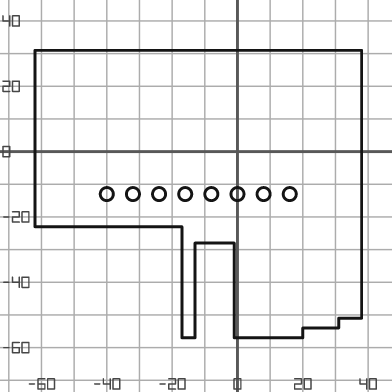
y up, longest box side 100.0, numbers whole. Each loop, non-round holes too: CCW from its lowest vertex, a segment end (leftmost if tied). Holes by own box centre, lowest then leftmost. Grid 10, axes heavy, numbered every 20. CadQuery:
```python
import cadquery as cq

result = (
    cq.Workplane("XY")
    .moveTo(-17.0, -57.0)
    .lineTo(-13.0, -57.0)
    .lineTo(-13.0, -28.0)
    .lineTo(-1.0, -28.0)
    .lineTo(-1.0, -57.0)
    .lineTo(20.0, -57.0)
    .lineTo(20.0, -54.0)
    .lineTo(31.0, -54.0)
    .lineTo(31.0, -51.0)
    .lineTo(38.0, -51.0)
    .lineTo(38.0, 31.0)
    .lineTo(-62.0, 31.0)
    .lineTo(-62.0, -23.0)
    .lineTo(-17.0, -23.0)
    .close()
    .moveTo(-40.0, -13.0)
    .circle(2.0)
    .moveTo(-32.0, -13.0)
    .circle(2.0)
    .moveTo(-24.0, -13.0)
    .circle(2.0)
    .moveTo(-16.0, -13.0)
    .circle(2.0)
    .moveTo(-8.0, -13.0)
    .circle(2.0)
    .moveTo(0.0, -13.0)
    .circle(2.0)
    .moveTo(8.0, -13.0)
    .circle(2.0)
    .moveTo(16.0, -13.0)
    .circle(2.0)
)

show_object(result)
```